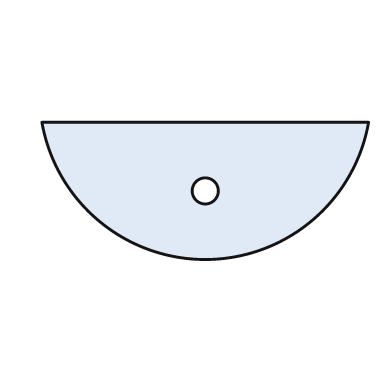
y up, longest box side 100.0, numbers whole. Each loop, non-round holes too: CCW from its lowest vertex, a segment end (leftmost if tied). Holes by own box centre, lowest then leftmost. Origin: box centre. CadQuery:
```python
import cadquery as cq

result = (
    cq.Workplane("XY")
    .moveTo(-50.0, 21.0)
    .threePointArc((0.0, -21.0), (50.0, 21.0))
    .close()
    .moveTo(0.0, 0.0)
    .circle(4.0)
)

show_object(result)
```